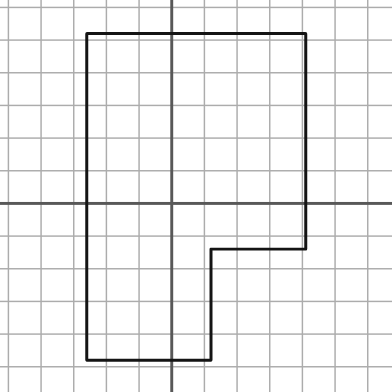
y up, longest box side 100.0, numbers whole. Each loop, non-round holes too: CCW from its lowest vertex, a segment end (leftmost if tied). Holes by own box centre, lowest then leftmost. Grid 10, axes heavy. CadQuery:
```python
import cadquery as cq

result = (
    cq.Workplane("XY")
    .moveTo(-26.0, -48.0)
    .lineTo(12.0, -48.0)
    .lineTo(12.0, -14.0)
    .lineTo(41.0, -14.0)
    .lineTo(41.0, 52.0)
    .lineTo(-26.0, 52.0)
    .close()
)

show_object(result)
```